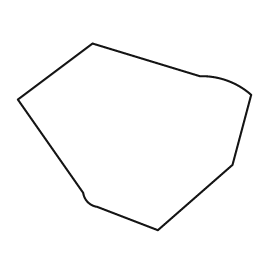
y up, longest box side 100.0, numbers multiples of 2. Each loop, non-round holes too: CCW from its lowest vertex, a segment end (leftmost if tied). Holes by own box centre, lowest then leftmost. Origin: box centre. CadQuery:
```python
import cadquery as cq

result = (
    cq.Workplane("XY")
    .moveTo(10.0, -40.0)
    .lineTo(42.0, -12.0)
    .lineTo(50.0, 18.0)
    .threePointArc((40.0, 24.0), (28.0, 26.0))
    .lineTo(-18.0, 40.0)
    .lineTo(-50.0, 16.0)
    .lineTo(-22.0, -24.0)
    .threePointArc((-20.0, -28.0), (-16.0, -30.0))
    .close()
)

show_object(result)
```